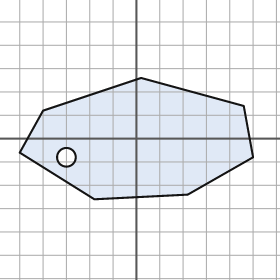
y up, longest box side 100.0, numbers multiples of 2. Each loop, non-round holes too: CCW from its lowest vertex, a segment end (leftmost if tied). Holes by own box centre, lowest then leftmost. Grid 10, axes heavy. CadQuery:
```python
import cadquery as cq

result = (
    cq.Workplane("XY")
    .moveTo(-18.0, -26.0)
    .lineTo(22.0, -24.0)
    .lineTo(50.0, -8.0)
    .lineTo(46.0, 14.0)
    .lineTo(2.0, 26.0)
    .lineTo(-40.0, 12.0)
    .lineTo(-50.0, -6.0)
    .close()
    .moveTo(-30.0, -8.0)
    .circle(4.0)
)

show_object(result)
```